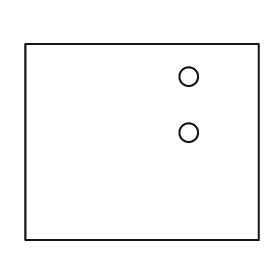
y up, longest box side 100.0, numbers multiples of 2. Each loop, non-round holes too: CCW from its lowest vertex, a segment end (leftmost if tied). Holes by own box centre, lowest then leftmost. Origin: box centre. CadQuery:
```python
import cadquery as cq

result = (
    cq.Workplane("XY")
    .moveTo(-50.0, -42.0)
    .lineTo(50.0, -42.0)
    .lineTo(50.0, 42.0)
    .lineTo(-50.0, 42.0)
    .close()
    .moveTo(20.0, 4.0)
    .circle(4.0)
    .moveTo(20.0, 28.0)
    .circle(4.0)
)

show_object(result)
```